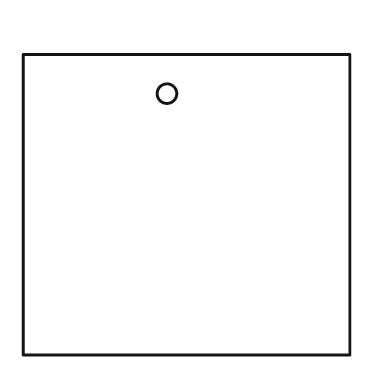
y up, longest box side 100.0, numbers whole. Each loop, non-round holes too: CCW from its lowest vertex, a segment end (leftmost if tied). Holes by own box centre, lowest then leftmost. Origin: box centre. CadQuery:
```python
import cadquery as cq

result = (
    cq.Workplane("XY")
    .moveTo(-50.0, -46.0)
    .lineTo(50.0, -46.0)
    .lineTo(50.0, 46.0)
    .lineTo(-50.0, 46.0)
    .close()
    .moveTo(-6.0, 34.0)
    .circle(3.0)
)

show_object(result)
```